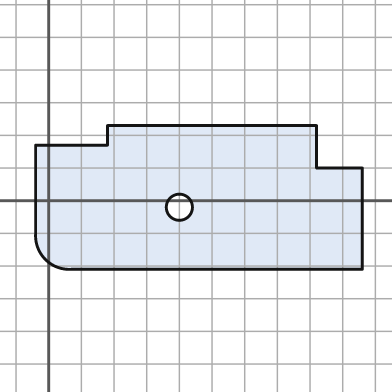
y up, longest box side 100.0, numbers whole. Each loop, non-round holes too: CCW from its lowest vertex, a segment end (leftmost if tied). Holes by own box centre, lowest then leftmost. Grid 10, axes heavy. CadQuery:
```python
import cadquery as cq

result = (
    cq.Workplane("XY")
    .moveTo(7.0, -21.0)
    .lineTo(96.0, -21.0)
    .lineTo(96.0, 10.0)
    .lineTo(82.0, 10.0)
    .lineTo(82.0, 23.0)
    .lineTo(18.0, 23.0)
    .lineTo(18.0, 17.0)
    .lineTo(-4.0, 17.0)
    .lineTo(-4.0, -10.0)
    .threePointArc((-1.0, -18.0), (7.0, -21.0))
    .close()
    .moveTo(40.0, -2.0)
    .circle(4.0)
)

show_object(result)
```